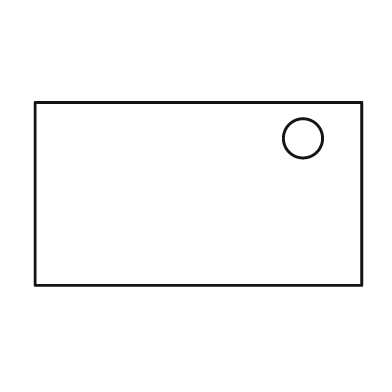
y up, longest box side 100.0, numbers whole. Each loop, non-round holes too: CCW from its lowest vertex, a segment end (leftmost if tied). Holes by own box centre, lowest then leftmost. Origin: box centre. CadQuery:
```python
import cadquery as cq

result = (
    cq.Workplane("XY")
    .moveTo(-50.0, -28.0)
    .lineTo(50.0, -28.0)
    .lineTo(50.0, 28.0)
    .lineTo(-50.0, 28.0)
    .close()
    .moveTo(32.0, 17.0)
    .circle(6.0)
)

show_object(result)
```